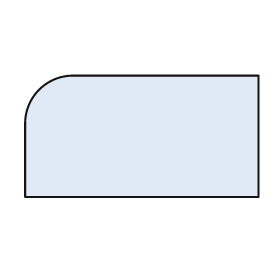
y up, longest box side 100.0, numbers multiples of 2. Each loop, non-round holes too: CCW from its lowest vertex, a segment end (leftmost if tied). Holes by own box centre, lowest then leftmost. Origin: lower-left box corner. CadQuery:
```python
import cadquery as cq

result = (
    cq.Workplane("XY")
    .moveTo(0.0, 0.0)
    .lineTo(100.0, 0.0)
    .lineTo(100.0, 52.0)
    .lineTo(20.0, 52.0)
    .threePointArc((6.0, 46.0), (0.0, 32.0))
    .close()
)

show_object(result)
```